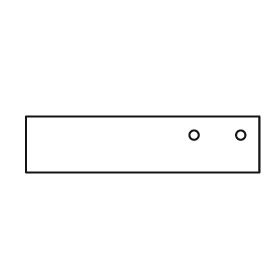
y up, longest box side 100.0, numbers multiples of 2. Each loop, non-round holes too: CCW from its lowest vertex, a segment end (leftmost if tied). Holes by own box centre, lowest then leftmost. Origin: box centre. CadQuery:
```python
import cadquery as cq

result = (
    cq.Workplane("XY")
    .moveTo(-50.0, -12.0)
    .lineTo(50.0, -12.0)
    .lineTo(50.0, 12.0)
    .lineTo(-50.0, 12.0)
    .close()
    .moveTo(22.0, 4.0)
    .circle(2.0)
    .moveTo(42.0, 4.0)
    .circle(2.0)
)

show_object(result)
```